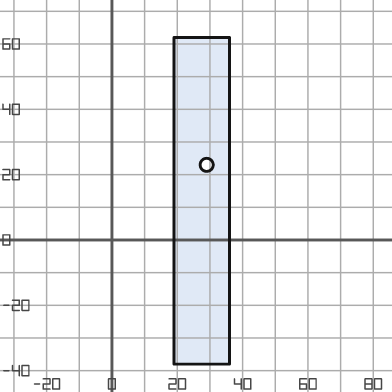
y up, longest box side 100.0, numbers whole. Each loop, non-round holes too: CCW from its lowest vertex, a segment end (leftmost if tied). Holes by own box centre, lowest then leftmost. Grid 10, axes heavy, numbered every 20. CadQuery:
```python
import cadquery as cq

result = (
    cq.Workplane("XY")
    .moveTo(19.0, -38.0)
    .lineTo(36.0, -38.0)
    .lineTo(36.0, 62.0)
    .lineTo(19.0, 62.0)
    .close()
    .moveTo(29.0, 23.0)
    .circle(2.0)
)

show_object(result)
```